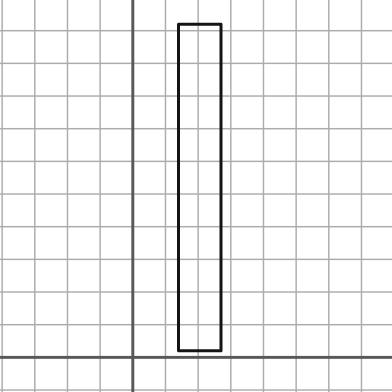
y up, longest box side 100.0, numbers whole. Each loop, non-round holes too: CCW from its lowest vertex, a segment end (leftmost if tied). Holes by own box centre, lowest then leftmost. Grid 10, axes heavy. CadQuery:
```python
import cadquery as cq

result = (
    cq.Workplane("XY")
    .moveTo(14.0, 2.0)
    .lineTo(27.0, 2.0)
    .lineTo(27.0, 102.0)
    .lineTo(14.0, 102.0)
    .close()
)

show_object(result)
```